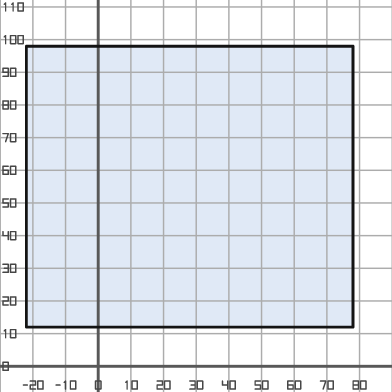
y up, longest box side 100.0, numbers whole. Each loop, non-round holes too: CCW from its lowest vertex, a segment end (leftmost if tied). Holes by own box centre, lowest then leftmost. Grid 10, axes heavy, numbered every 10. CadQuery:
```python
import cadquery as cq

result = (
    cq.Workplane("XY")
    .moveTo(-22.0, 12.0)
    .lineTo(78.0, 12.0)
    .lineTo(78.0, 98.0)
    .lineTo(-22.0, 98.0)
    .close()
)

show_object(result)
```